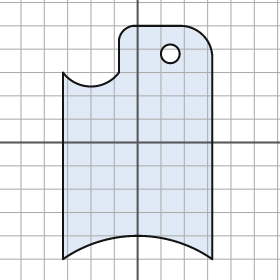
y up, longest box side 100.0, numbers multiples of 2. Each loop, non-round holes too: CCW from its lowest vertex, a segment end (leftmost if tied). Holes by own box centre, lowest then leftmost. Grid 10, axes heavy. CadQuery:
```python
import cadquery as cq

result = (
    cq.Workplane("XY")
    .moveTo(-32.0, -50.0)
    .threePointArc((0.0, -40.0), (32.0, -50.0))
    .lineTo(32.0, 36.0)
    .threePointArc((28.0, 46.0), (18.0, 50.0))
    .lineTo(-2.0, 50.0)
    .threePointArc((-6.0, 48.0), (-8.0, 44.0))
    .lineTo(-8.0, 30.0)
    .threePointArc((-20.0, 24.0), (-32.0, 30.0))
    .close()
    .moveTo(14.0, 38.0)
    .circle(4.0)
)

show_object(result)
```